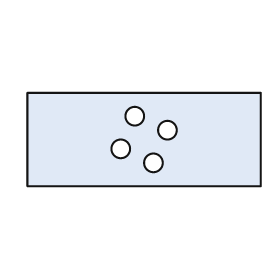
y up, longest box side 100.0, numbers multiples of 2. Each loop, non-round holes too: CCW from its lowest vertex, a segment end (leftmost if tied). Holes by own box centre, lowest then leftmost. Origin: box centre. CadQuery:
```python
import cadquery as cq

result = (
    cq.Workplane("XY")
    .moveTo(-50.0, -20.0)
    .lineTo(50.0, -20.0)
    .lineTo(50.0, 20.0)
    .lineTo(-50.0, 20.0)
    .close()
    .moveTo(4.0, -10.0)
    .circle(4.0)
    .moveTo(-10.0, -4.0)
    .circle(4.0)
    .moveTo(10.0, 4.0)
    .circle(4.0)
    .moveTo(-4.0, 10.0)
    .circle(4.0)
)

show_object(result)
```